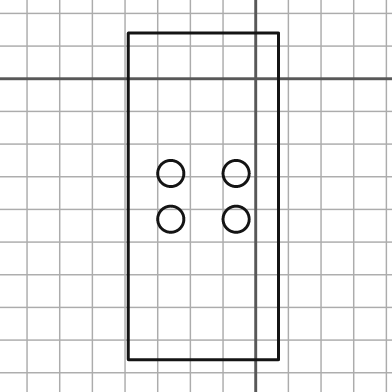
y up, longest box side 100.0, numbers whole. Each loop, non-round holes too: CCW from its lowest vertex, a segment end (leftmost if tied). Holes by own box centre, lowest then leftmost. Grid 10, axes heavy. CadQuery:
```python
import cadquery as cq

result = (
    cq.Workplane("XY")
    .moveTo(-39.0, -86.0)
    .lineTo(7.0, -86.0)
    .lineTo(7.0, 14.0)
    .lineTo(-39.0, 14.0)
    .close()
    .moveTo(-26.0, -43.0)
    .circle(4.0)
    .moveTo(-6.0, -43.0)
    .circle(4.0)
    .moveTo(-26.0, -29.0)
    .circle(4.0)
    .moveTo(-6.0, -29.0)
    .circle(4.0)
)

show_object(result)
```